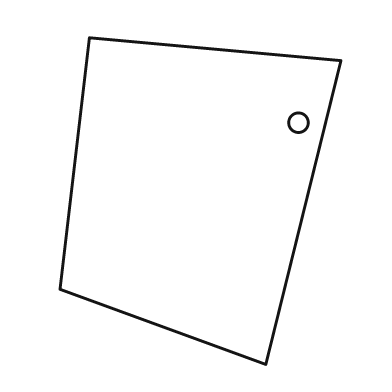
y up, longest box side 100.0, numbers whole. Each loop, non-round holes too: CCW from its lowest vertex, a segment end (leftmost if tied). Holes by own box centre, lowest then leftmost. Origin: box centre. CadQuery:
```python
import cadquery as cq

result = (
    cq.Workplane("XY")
    .moveTo(20.0, -50.0)
    .lineTo(43.0, 43.0)
    .lineTo(-34.0, 50.0)
    .lineTo(-43.0, -27.0)
    .close()
    .moveTo(30.0, 24.0)
    .circle(3.0)
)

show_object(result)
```